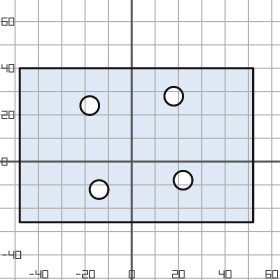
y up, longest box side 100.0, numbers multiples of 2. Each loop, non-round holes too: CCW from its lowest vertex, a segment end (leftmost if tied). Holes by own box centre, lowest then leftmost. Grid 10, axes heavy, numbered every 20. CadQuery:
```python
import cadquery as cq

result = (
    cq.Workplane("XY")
    .moveTo(-48.0, -26.0)
    .lineTo(52.0, -26.0)
    .lineTo(52.0, 40.0)
    .lineTo(-48.0, 40.0)
    .close()
    .moveTo(-14.0, -12.0)
    .circle(4.0)
    .moveTo(22.0, -8.0)
    .circle(4.0)
    .moveTo(-18.0, 24.0)
    .circle(4.0)
    .moveTo(18.0, 28.0)
    .circle(4.0)
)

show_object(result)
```